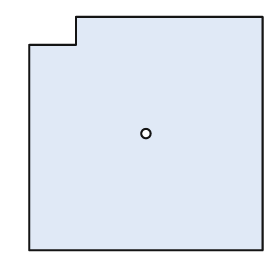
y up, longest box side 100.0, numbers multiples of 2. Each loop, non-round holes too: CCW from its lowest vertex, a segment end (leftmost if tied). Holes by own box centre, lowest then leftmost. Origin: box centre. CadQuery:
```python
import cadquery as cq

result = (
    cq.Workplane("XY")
    .moveTo(-50.0, -50.0)
    .lineTo(50.0, -50.0)
    .lineTo(50.0, 50.0)
    .lineTo(-30.0, 50.0)
    .lineTo(-30.0, 38.0)
    .lineTo(-50.0, 38.0)
    .close()
    .moveTo(0.0, 0.0)
    .circle(2.0)
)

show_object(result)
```